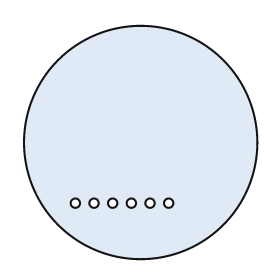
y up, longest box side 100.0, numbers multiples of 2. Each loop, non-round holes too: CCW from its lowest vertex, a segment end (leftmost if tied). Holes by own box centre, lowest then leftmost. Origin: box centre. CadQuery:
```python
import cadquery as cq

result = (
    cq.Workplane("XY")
    .moveTo(0.0, 0.0)
    .circle(50.0)
    .moveTo(-28.0, -26.0)
    .circle(2.0)
    .moveTo(-20.0, -26.0)
    .circle(2.0)
    .moveTo(-12.0, -26.0)
    .circle(2.0)
    .moveTo(-4.0, -26.0)
    .circle(2.0)
    .moveTo(4.0, -26.0)
    .circle(2.0)
    .moveTo(12.0, -26.0)
    .circle(2.0)
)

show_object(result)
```